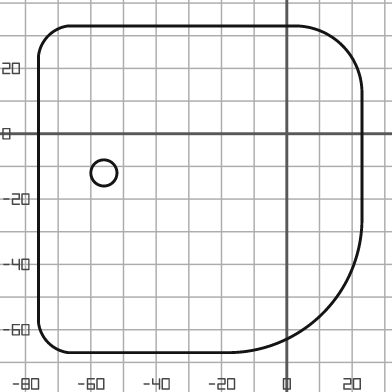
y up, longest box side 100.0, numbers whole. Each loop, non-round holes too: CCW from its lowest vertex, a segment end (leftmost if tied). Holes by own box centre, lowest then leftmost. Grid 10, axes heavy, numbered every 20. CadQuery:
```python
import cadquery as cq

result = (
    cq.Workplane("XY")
    .moveTo(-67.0, -67.0)
    .lineTo(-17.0, -67.0)
    .threePointArc((11.0, -55.0), (23.0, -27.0))
    .lineTo(23.0, 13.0)
    .threePointArc((17.0, 27.0), (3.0, 33.0))
    .lineTo(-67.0, 33.0)
    .threePointArc((-73.0, 30.0), (-76.0, 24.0))
    .lineTo(-76.0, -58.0)
    .threePointArc((-73.0, -64.0), (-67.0, -67.0))
    .close()
    .moveTo(-56.0, -12.0)
    .circle(4.0)
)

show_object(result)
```